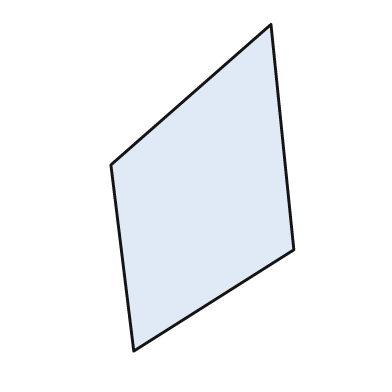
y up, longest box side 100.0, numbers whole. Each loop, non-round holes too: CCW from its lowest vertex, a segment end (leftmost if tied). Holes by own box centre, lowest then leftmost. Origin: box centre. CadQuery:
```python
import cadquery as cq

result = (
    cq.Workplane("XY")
    .moveTo(-21.0, -50.0)
    .lineTo(28.0, -19.0)
    .lineTo(21.0, 50.0)
    .lineTo(-28.0, 7.0)
    .close()
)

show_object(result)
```